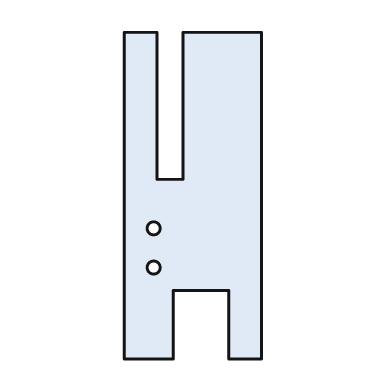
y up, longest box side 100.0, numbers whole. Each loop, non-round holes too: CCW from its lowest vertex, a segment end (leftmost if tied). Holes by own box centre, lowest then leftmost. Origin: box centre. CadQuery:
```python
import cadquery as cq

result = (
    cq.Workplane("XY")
    .moveTo(-21.0, -50.0)
    .lineTo(-6.0, -50.0)
    .lineTo(-6.0, -29.0)
    .lineTo(11.0, -29.0)
    .lineTo(11.0, -50.0)
    .lineTo(21.0, -50.0)
    .lineTo(21.0, 50.0)
    .lineTo(-3.0, 50.0)
    .lineTo(-3.0, 5.0)
    .lineTo(-11.0, 5.0)
    .lineTo(-11.0, 50.0)
    .lineTo(-21.0, 50.0)
    .close()
    .moveTo(-12.0, -22.0)
    .circle(2.0)
    .moveTo(-12.0, -10.0)
    .circle(2.0)
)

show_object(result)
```